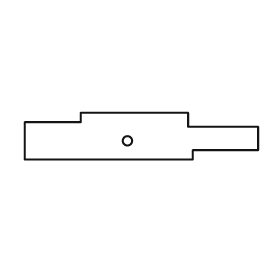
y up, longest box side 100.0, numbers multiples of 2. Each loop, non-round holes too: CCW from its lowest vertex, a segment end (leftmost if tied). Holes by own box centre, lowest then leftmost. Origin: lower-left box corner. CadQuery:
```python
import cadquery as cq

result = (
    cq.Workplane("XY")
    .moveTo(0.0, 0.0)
    .lineTo(72.0, 0.0)
    .lineTo(72.0, 4.0)
    .lineTo(100.0, 4.0)
    .lineTo(100.0, 14.0)
    .lineTo(70.0, 14.0)
    .lineTo(70.0, 20.0)
    .lineTo(24.0, 20.0)
    .lineTo(24.0, 16.0)
    .lineTo(0.0, 16.0)
    .close()
    .moveTo(44.0, 8.0)
    .circle(2.0)
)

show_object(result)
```